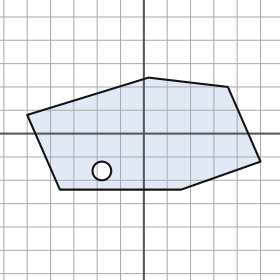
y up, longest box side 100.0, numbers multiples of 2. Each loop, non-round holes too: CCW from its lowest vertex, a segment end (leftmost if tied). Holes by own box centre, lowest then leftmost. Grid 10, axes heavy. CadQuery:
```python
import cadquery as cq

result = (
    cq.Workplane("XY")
    .moveTo(-36.0, -24.0)
    .lineTo(16.0, -24.0)
    .lineTo(50.0, -12.0)
    .lineTo(36.0, 20.0)
    .lineTo(2.0, 24.0)
    .lineTo(-50.0, 8.0)
    .close()
    .moveTo(-18.0, -16.0)
    .circle(4.0)
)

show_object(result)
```